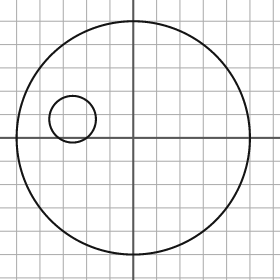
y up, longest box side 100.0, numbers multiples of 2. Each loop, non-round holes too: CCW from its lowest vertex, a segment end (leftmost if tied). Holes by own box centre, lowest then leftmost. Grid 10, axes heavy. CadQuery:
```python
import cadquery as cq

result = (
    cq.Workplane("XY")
    .moveTo(0.0, 0.0)
    .circle(50.0)
    .moveTo(-26.0, 8.0)
    .circle(10.0)
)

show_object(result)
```